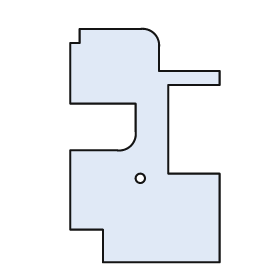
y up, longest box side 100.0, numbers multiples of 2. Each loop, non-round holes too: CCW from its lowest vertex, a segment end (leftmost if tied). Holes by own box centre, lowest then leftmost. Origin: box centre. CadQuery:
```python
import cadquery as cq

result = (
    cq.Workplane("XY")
    .moveTo(-18.0, -50.0)
    .lineTo(32.0, -50.0)
    .lineTo(32.0, -12.0)
    .lineTo(10.0, -12.0)
    .lineTo(10.0, 26.0)
    .lineTo(32.0, 26.0)
    .lineTo(32.0, 32.0)
    .lineTo(6.0, 32.0)
    .lineTo(6.0, 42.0)
    .threePointArc((4.0, 48.0), (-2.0, 50.0))
    .lineTo(-28.0, 50.0)
    .lineTo(-28.0, 44.0)
    .lineTo(-32.0, 44.0)
    .lineTo(-32.0, 18.0)
    .lineTo(-4.0, 18.0)
    .lineTo(-4.0, 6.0)
    .threePointArc((-6.0, 0.0), (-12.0, -2.0))
    .lineTo(-32.0, -2.0)
    .lineTo(-32.0, -36.0)
    .lineTo(-18.0, -36.0)
    .close()
    .moveTo(-2.0, -14.0)
    .circle(2.0)
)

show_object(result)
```